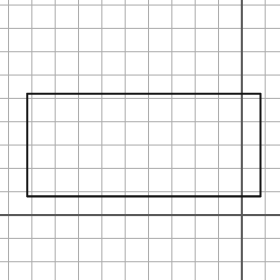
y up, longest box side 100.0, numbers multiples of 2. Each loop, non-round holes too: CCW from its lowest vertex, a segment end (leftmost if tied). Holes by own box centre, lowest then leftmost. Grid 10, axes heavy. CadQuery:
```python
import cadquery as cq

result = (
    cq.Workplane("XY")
    .moveTo(-92.0, 8.0)
    .lineTo(8.0, 8.0)
    .lineTo(8.0, 52.0)
    .lineTo(-92.0, 52.0)
    .close()
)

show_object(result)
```